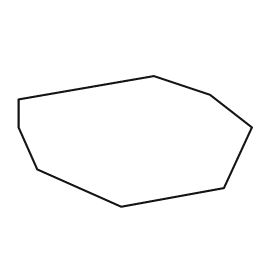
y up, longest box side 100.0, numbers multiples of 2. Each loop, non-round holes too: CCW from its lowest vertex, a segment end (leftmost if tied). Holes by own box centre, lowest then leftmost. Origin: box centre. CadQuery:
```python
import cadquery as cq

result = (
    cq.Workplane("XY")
    .moveTo(-6.0, -28.0)
    .lineTo(38.0, -20.0)
    .lineTo(50.0, 6.0)
    .lineTo(32.0, 20.0)
    .lineTo(8.0, 28.0)
    .lineTo(-50.0, 18.0)
    .lineTo(-50.0, 6.0)
    .lineTo(-42.0, -12.0)
    .close()
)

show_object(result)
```